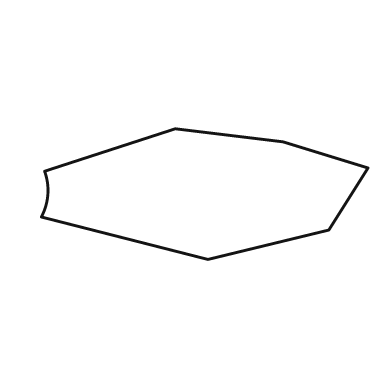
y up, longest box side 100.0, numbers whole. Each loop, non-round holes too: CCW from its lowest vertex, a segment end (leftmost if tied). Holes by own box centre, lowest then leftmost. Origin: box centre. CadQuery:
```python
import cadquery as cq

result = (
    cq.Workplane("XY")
    .moveTo(1.0, -20.0)
    .lineTo(38.0, -11.0)
    .lineTo(50.0, 8.0)
    .lineTo(24.0, 16.0)
    .lineTo(-9.0, 20.0)
    .lineTo(-49.0, 7.0)
    .threePointArc((-48.0, 0.0), (-50.0, -7.0))
    .close()
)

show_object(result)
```